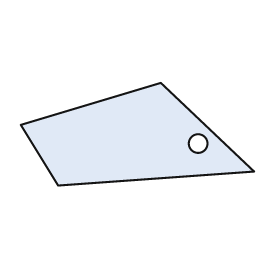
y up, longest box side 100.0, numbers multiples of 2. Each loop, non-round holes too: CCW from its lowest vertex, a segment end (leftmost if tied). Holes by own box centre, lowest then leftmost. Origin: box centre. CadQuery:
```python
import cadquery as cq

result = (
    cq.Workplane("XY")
    .moveTo(-34.0, -22.0)
    .lineTo(50.0, -16.0)
    .lineTo(10.0, 22.0)
    .lineTo(-50.0, 4.0)
    .close()
    .moveTo(26.0, -4.0)
    .circle(4.0)
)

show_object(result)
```